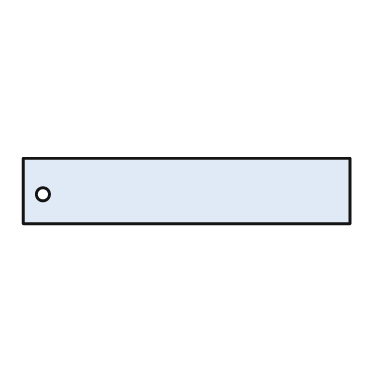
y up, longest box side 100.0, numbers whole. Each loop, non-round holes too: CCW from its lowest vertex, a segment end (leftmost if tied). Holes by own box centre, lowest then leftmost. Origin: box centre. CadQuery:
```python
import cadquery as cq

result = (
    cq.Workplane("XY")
    .moveTo(-50.0, -10.0)
    .lineTo(50.0, -10.0)
    .lineTo(50.0, 10.0)
    .lineTo(-50.0, 10.0)
    .close()
    .moveTo(-44.0, -1.0)
    .circle(2.0)
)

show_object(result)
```